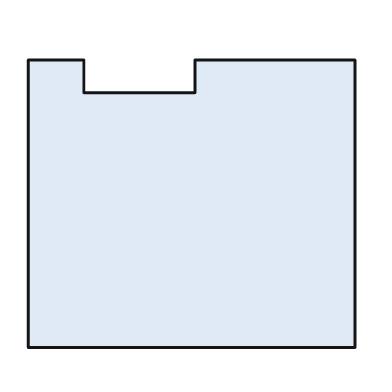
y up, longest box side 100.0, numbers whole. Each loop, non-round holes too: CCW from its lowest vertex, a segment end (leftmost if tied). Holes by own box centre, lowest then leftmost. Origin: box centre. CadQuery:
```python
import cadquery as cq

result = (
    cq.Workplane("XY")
    .moveTo(-50.0, -44.0)
    .lineTo(50.0, -44.0)
    .lineTo(50.0, 44.0)
    .lineTo(1.0, 44.0)
    .lineTo(1.0, 34.0)
    .lineTo(-33.0, 34.0)
    .lineTo(-33.0, 44.0)
    .lineTo(-50.0, 44.0)
    .close()
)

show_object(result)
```